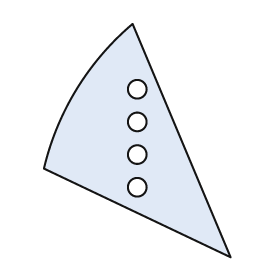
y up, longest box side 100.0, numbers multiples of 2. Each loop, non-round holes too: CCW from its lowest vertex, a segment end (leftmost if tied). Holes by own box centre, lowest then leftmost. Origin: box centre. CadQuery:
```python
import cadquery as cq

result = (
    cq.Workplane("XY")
    .moveTo(40.0, -50.0)
    .lineTo(-2.0, 50.0)
    .threePointArc((-26.0, 22.0), (-40.0, -12.0))
    .close()
    .moveTo(0.0, -20.0)
    .circle(4.0)
    .moveTo(0.0, -6.0)
    .circle(4.0)
    .moveTo(0.0, 8.0)
    .circle(4.0)
    .moveTo(0.0, 22.0)
    .circle(4.0)
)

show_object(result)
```